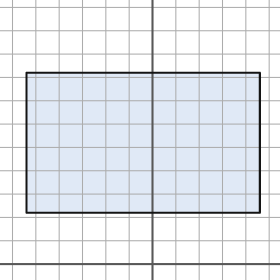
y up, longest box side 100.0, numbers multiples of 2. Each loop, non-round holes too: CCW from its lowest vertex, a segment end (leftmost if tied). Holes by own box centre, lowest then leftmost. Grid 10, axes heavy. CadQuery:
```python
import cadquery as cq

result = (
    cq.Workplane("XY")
    .moveTo(-54.0, 22.0)
    .lineTo(46.0, 22.0)
    .lineTo(46.0, 82.0)
    .lineTo(-54.0, 82.0)
    .close()
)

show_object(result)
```